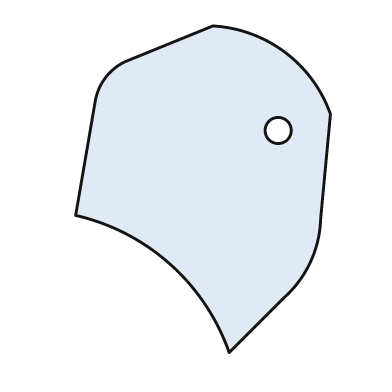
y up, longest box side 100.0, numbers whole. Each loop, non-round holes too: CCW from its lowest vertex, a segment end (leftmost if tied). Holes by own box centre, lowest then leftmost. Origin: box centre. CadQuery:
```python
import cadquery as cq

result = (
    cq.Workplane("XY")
    .moveTo(8.0, -50.0)
    .lineTo(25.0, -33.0)
    .threePointArc((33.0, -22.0), (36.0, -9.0))
    .lineTo(39.0, 23.0)
    .threePointArc((25.0, 42.0), (3.0, 50.0))
    .lineTo(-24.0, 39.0)
    .threePointArc((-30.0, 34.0), (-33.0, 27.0))
    .lineTo(-39.0, -8.0)
    .threePointArc((-10.0, -23.0), (8.0, -50.0))
    .close()
    .moveTo(23.0, 18.0)
    .circle(4.0)
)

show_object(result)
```